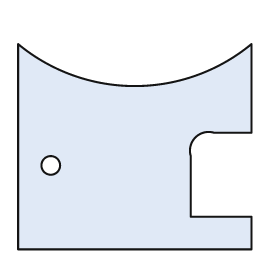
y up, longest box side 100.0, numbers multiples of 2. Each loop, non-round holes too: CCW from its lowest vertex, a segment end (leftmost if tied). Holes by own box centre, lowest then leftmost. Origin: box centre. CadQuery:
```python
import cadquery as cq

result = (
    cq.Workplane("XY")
    .moveTo(-50.0, -44.0)
    .lineTo(50.0, -44.0)
    .lineTo(50.0, -30.0)
    .lineTo(24.0, -30.0)
    .lineTo(24.0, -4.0)
    .threePointArc((26.0, 4.0), (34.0, 6.0))
    .lineTo(50.0, 6.0)
    .lineTo(50.0, 44.0)
    .threePointArc((0.0, 26.0), (-50.0, 44.0))
    .close()
    .moveTo(-36.0, -8.0)
    .circle(4.0)
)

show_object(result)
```